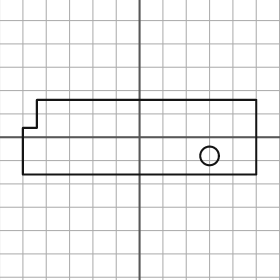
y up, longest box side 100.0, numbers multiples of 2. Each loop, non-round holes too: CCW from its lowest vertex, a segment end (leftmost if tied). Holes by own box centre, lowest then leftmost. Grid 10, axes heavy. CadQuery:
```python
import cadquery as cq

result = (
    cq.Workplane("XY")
    .moveTo(-50.0, -16.0)
    .lineTo(50.0, -16.0)
    .lineTo(50.0, 16.0)
    .lineTo(-44.0, 16.0)
    .lineTo(-44.0, 4.0)
    .lineTo(-50.0, 4.0)
    .close()
    .moveTo(30.0, -8.0)
    .circle(4.0)
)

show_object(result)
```